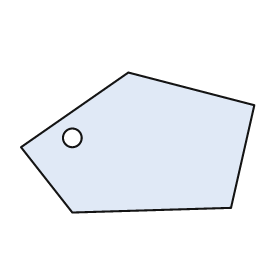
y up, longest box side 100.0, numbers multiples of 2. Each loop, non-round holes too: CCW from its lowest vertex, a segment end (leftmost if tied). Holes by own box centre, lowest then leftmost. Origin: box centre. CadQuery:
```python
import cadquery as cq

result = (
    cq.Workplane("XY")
    .moveTo(-28.0, -30.0)
    .lineTo(40.0, -28.0)
    .lineTo(50.0, 16.0)
    .lineTo(-4.0, 30.0)
    .lineTo(-50.0, -2.0)
    .close()
    .moveTo(-28.0, 2.0)
    .circle(4.0)
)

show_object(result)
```